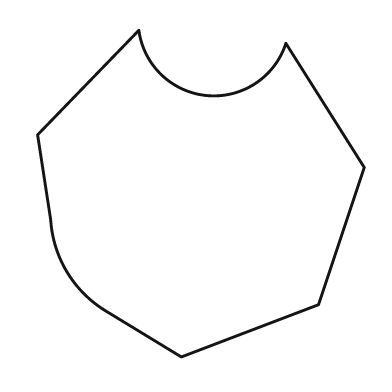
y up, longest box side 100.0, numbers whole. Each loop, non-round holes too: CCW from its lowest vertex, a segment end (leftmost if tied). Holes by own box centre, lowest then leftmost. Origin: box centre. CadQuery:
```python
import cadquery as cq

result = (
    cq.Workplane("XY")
    .moveTo(-6.0, -50.0)
    .lineTo(36.0, -34.0)
    .lineTo(50.0, 8.0)
    .lineTo(26.0, 46.0)
    .threePointArc((2.0, 30.0), (-19.0, 50.0))
    .lineTo(-50.0, 18.0)
    .lineTo(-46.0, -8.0)
    .threePointArc((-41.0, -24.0), (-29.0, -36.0))
    .close()
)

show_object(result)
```